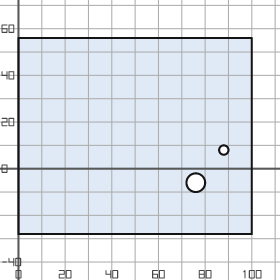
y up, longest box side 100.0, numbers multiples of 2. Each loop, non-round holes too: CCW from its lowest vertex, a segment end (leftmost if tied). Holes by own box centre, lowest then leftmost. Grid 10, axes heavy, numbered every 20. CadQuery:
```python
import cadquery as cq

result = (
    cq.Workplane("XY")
    .moveTo(0.0, -28.0)
    .lineTo(100.0, -28.0)
    .lineTo(100.0, 56.0)
    .lineTo(0.0, 56.0)
    .close()
    .moveTo(76.0, -6.0)
    .circle(4.0)
    .moveTo(88.0, 8.0)
    .circle(2.0)
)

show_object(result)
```